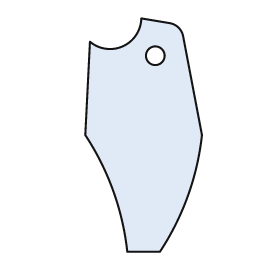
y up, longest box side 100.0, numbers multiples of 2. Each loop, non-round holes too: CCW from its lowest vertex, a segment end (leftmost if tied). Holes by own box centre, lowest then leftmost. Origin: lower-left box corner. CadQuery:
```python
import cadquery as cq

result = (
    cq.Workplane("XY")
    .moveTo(18.0, 0.0)
    .lineTo(32.0, 0.0)
    .threePointArc((44.0, 24.0), (50.0, 50.0))
    .lineTo(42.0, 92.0)
    .threePointArc((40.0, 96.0), (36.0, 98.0))
    .lineTo(24.0, 100.0)
    .threePointArc((16.0, 88.0), (2.0, 90.0))
    .lineTo(0.0, 50.0)
    .threePointArc((12.0, 26.0), (18.0, 0.0))
    .close()
    .moveTo(30.0, 84.0)
    .circle(4.0)
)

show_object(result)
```